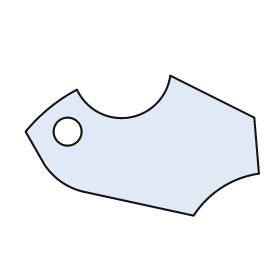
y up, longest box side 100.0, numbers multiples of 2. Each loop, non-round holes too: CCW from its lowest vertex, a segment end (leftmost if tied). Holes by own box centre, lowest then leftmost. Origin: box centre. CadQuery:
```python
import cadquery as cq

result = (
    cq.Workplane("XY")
    .moveTo(22.0, -30.0)
    .threePointArc((34.0, -18.0), (50.0, -12.0))
    .lineTo(48.0, 12.0)
    .lineTo(12.0, 30.0)
    .threePointArc((-6.0, 12.0), (-28.0, 24.0))
    .threePointArc((-40.0, 16.0), (-50.0, 6.0))
    .lineTo(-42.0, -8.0)
    .threePointArc((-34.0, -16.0), (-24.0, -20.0))
    .close()
    .moveTo(-32.0, 6.0)
    .circle(6.0)
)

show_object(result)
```